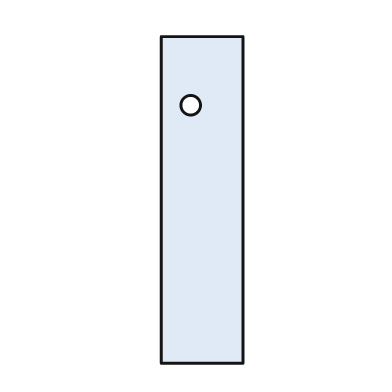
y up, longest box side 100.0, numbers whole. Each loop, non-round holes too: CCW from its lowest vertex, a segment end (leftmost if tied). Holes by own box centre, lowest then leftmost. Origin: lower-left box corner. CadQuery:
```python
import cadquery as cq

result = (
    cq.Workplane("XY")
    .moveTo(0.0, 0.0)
    .lineTo(25.0, 0.0)
    .lineTo(25.0, 100.0)
    .lineTo(0.0, 100.0)
    .close()
    .moveTo(9.0, 79.0)
    .circle(3.0)
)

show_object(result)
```